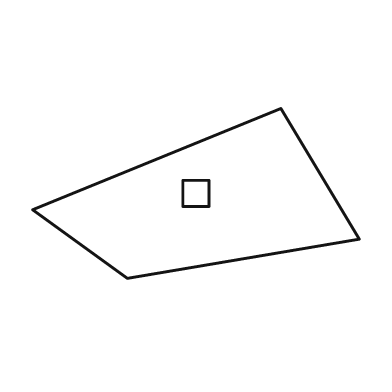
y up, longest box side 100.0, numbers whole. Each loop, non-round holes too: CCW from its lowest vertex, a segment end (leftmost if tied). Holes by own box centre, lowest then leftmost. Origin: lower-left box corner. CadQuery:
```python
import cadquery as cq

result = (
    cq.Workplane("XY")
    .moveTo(29.0, 0.0)
    .lineTo(100.0, 12.0)
    .lineTo(76.0, 52.0)
    .lineTo(0.0, 21.0)
    .close()
    .moveTo(46.0, 22.0)
    .lineTo(54.0, 22.0)
    .lineTo(54.0, 30.0)
    .lineTo(46.0, 30.0)
    .close()
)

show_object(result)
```